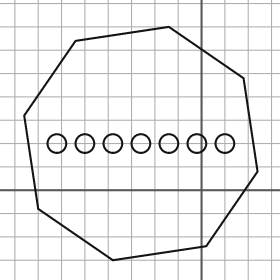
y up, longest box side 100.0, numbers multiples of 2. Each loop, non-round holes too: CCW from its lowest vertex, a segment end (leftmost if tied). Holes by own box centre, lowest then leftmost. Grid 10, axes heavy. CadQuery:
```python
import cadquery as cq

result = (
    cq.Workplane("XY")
    .moveTo(-38.0, -30.0)
    .lineTo(2.0, -24.0)
    .lineTo(24.0, 8.0)
    .lineTo(18.0, 48.0)
    .lineTo(-14.0, 70.0)
    .lineTo(-54.0, 64.0)
    .lineTo(-76.0, 32.0)
    .lineTo(-70.0, -8.0)
    .close()
    .moveTo(-62.0, 20.0)
    .circle(4.0)
    .moveTo(-50.0, 20.0)
    .circle(4.0)
    .moveTo(-38.0, 20.0)
    .circle(4.0)
    .moveTo(-26.0, 20.0)
    .circle(4.0)
    .moveTo(-14.0, 20.0)
    .circle(4.0)
    .moveTo(-2.0, 20.0)
    .circle(4.0)
    .moveTo(10.0, 20.0)
    .circle(4.0)
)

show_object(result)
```